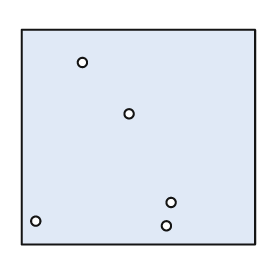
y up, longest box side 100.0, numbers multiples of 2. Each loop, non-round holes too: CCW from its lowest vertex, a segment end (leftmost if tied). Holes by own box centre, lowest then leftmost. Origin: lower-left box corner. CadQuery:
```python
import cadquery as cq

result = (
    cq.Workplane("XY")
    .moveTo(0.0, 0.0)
    .lineTo(100.0, 0.0)
    .lineTo(100.0, 92.0)
    .lineTo(0.0, 92.0)
    .close()
    .moveTo(62.0, 8.0)
    .circle(2.0)
    .moveTo(6.0, 10.0)
    .circle(2.0)
    .moveTo(64.0, 18.0)
    .circle(2.0)
    .moveTo(46.0, 56.0)
    .circle(2.0)
    .moveTo(26.0, 78.0)
    .circle(2.0)
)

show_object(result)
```